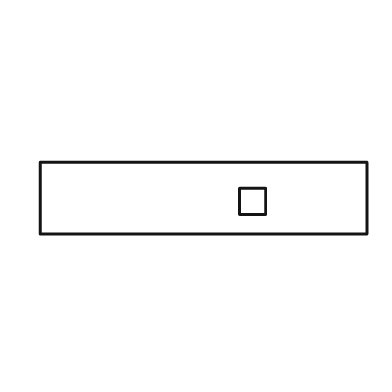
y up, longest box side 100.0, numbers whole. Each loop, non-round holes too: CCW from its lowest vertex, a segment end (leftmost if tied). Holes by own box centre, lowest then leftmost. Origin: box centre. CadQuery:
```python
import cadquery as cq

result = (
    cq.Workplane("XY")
    .moveTo(-50.0, -11.0)
    .lineTo(50.0, -11.0)
    .lineTo(50.0, 11.0)
    .lineTo(-50.0, 11.0)
    .close()
    .moveTo(11.0, -5.0)
    .lineTo(19.0, -5.0)
    .lineTo(19.0, 3.0)
    .lineTo(11.0, 3.0)
    .close()
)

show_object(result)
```